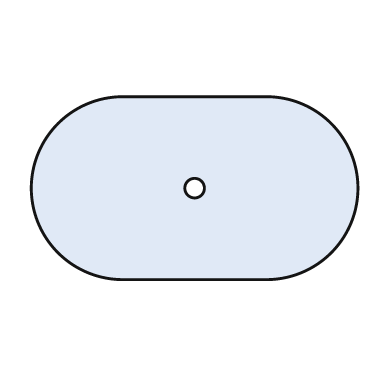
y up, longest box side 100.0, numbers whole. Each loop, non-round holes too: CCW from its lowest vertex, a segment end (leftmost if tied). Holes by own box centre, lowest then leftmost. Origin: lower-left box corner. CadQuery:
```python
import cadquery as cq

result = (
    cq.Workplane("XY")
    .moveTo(28.0, 0.0)
    .lineTo(72.0, 0.0)
    .threePointArc((100.0, 28.0), (72.0, 56.0))
    .lineTo(28.0, 56.0)
    .threePointArc((0.0, 28.0), (28.0, 0.0))
    .close()
    .moveTo(50.0, 28.0)
    .circle(3.0)
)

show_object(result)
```